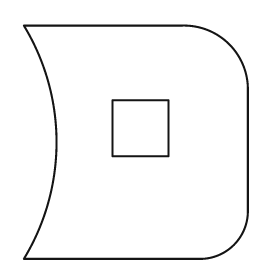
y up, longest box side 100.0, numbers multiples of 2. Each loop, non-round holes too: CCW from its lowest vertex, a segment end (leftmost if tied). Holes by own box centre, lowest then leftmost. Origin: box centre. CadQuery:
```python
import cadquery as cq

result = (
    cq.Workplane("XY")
    .moveTo(-48.0, -50.0)
    .lineTo(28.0, -50.0)
    .threePointArc((42.0, -44.0), (48.0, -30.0))
    .lineTo(48.0, 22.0)
    .threePointArc((40.0, 42.0), (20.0, 50.0))
    .lineTo(-48.0, 50.0)
    .threePointArc((-34.0, 0.0), (-48.0, -50.0))
    .close()
    .moveTo(-10.0, -6.0)
    .lineTo(14.0, -6.0)
    .lineTo(14.0, 18.0)
    .lineTo(-10.0, 18.0)
    .close()
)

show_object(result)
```